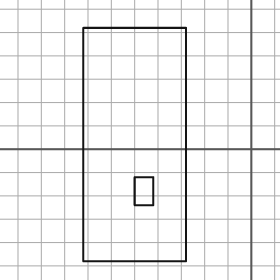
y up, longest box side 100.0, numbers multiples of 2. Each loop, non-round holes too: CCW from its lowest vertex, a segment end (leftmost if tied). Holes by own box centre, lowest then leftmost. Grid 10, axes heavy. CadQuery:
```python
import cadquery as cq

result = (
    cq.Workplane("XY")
    .moveTo(-72.0, -48.0)
    .lineTo(-28.0, -48.0)
    .lineTo(-28.0, 52.0)
    .lineTo(-72.0, 52.0)
    .close()
    .moveTo(-50.0, -24.0)
    .lineTo(-42.0, -24.0)
    .lineTo(-42.0, -12.0)
    .lineTo(-50.0, -12.0)
    .close()
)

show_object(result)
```